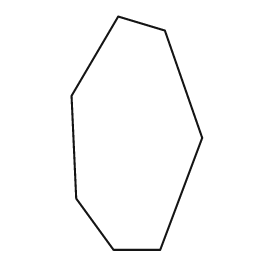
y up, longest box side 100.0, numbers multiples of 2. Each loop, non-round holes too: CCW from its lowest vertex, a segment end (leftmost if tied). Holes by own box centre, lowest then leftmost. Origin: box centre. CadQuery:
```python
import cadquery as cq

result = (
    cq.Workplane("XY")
    .moveTo(-10.0, -50.0)
    .lineTo(10.0, -50.0)
    .lineTo(28.0, -2.0)
    .lineTo(12.0, 44.0)
    .lineTo(-8.0, 50.0)
    .lineTo(-28.0, 16.0)
    .lineTo(-26.0, -28.0)
    .close()
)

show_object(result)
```